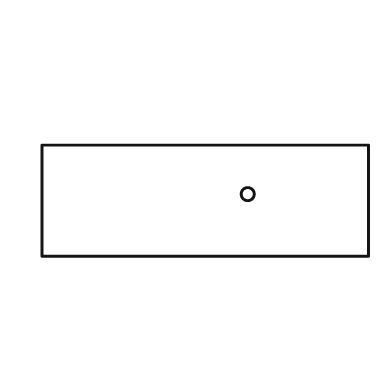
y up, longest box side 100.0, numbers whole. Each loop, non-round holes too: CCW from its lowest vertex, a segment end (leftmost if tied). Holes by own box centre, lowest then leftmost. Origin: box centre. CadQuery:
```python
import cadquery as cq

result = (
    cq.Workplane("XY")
    .moveTo(-50.0, -17.0)
    .lineTo(50.0, -17.0)
    .lineTo(50.0, 17.0)
    .lineTo(-50.0, 17.0)
    .close()
    .moveTo(13.0, 2.0)
    .circle(2.0)
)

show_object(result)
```